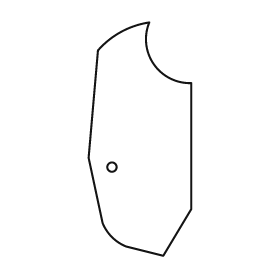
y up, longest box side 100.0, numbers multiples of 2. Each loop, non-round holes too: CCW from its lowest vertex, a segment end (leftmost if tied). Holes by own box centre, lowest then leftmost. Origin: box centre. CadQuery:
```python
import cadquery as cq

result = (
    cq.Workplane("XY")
    .moveTo(10.0, -50.0)
    .lineTo(22.0, -30.0)
    .lineTo(22.0, 24.0)
    .threePointArc((6.0, 32.0), (4.0, 50.0))
    .threePointArc((-8.0, 46.0), (-18.0, 38.0))
    .lineTo(-22.0, -8.0)
    .lineTo(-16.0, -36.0)
    .threePointArc((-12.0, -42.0), (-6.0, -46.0))
    .close()
    .moveTo(-12.0, -12.0)
    .circle(2.0)
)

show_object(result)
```